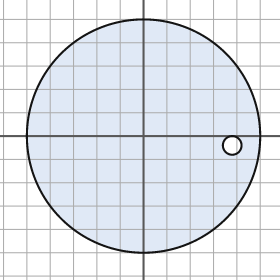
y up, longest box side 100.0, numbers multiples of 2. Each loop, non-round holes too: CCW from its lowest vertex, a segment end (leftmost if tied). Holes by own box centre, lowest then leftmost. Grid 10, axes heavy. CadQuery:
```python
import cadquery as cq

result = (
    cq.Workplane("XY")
    .moveTo(0.0, 0.0)
    .circle(50.0)
    .moveTo(38.0, -4.0)
    .circle(4.0)
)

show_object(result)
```